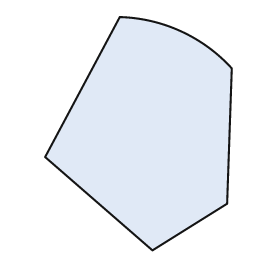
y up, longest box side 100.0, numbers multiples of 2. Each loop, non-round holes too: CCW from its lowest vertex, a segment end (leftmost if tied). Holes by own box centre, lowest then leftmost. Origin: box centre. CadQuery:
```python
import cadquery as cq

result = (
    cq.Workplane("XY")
    .moveTo(6.0, -50.0)
    .lineTo(38.0, -30.0)
    .lineTo(40.0, 28.0)
    .threePointArc((18.0, 44.0), (-8.0, 50.0))
    .lineTo(-40.0, -10.0)
    .close()
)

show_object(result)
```